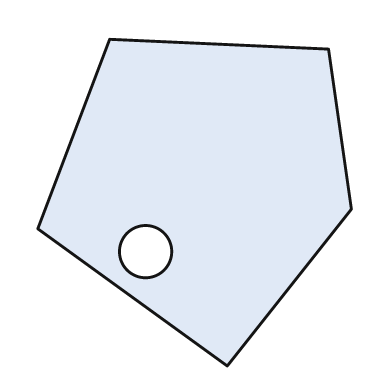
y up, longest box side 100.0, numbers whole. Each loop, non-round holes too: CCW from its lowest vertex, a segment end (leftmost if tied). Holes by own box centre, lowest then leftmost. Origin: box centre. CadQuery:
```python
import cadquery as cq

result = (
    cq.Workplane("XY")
    .moveTo(10.0, -50.0)
    .lineTo(48.0, -2.0)
    .lineTo(41.0, 47.0)
    .lineTo(-26.0, 50.0)
    .lineTo(-48.0, -8.0)
    .close()
    .moveTo(-15.0, -15.0)
    .circle(8.0)
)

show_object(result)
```